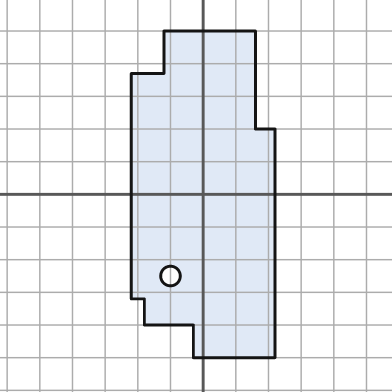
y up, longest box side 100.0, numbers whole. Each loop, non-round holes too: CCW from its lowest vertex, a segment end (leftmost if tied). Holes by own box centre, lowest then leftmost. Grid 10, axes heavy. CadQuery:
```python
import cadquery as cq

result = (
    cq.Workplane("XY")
    .moveTo(-3.0, -50.0)
    .lineTo(22.0, -50.0)
    .lineTo(22.0, 20.0)
    .lineTo(16.0, 20.0)
    .lineTo(16.0, 50.0)
    .lineTo(-12.0, 50.0)
    .lineTo(-12.0, 37.0)
    .lineTo(-22.0, 37.0)
    .lineTo(-22.0, -32.0)
    .lineTo(-18.0, -32.0)
    .lineTo(-18.0, -40.0)
    .lineTo(-3.0, -40.0)
    .close()
    .moveTo(-10.0, -25.0)
    .circle(3.0)
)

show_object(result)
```